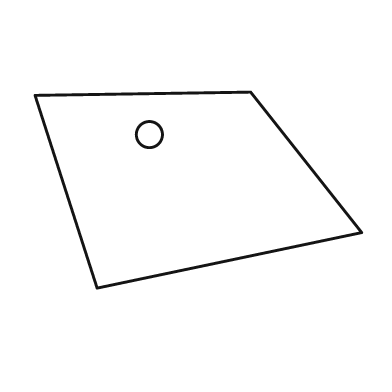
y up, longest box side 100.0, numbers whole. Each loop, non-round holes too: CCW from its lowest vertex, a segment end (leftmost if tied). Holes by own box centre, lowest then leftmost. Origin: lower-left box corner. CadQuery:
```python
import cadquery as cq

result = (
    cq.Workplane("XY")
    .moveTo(19.0, 0.0)
    .lineTo(100.0, 17.0)
    .lineTo(66.0, 60.0)
    .lineTo(0.0, 59.0)
    .close()
    .moveTo(35.0, 47.0)
    .circle(4.0)
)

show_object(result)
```